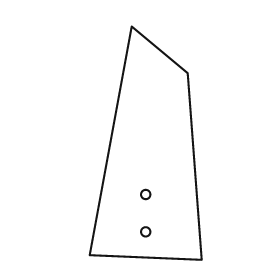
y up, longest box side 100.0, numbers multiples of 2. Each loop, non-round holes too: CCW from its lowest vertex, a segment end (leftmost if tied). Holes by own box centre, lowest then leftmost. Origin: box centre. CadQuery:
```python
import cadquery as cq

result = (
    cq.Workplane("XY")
    .moveTo(24.0, -50.0)
    .lineTo(18.0, 30.0)
    .lineTo(-6.0, 50.0)
    .lineTo(-24.0, -48.0)
    .close()
    .moveTo(0.0, -38.0)
    .circle(2.0)
    .moveTo(0.0, -22.0)
    .circle(2.0)
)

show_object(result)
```